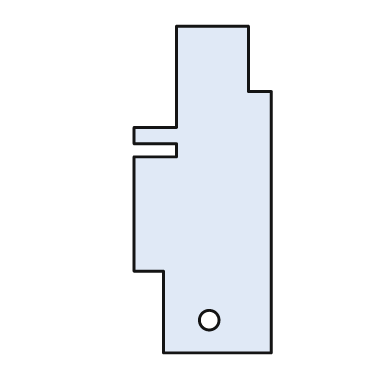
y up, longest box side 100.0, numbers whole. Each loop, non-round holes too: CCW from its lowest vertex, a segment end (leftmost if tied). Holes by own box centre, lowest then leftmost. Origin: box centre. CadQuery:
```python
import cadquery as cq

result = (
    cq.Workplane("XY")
    .moveTo(-12.0, -50.0)
    .lineTo(21.0, -50.0)
    .lineTo(21.0, 30.0)
    .lineTo(14.0, 30.0)
    .lineTo(14.0, 50.0)
    .lineTo(-8.0, 50.0)
    .lineTo(-8.0, 19.0)
    .lineTo(-21.0, 19.0)
    .lineTo(-21.0, 14.0)
    .lineTo(-8.0, 14.0)
    .lineTo(-8.0, 10.0)
    .lineTo(-21.0, 10.0)
    .lineTo(-21.0, -25.0)
    .lineTo(-12.0, -25.0)
    .close()
    .moveTo(2.0, -40.0)
    .circle(3.0)
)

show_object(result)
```